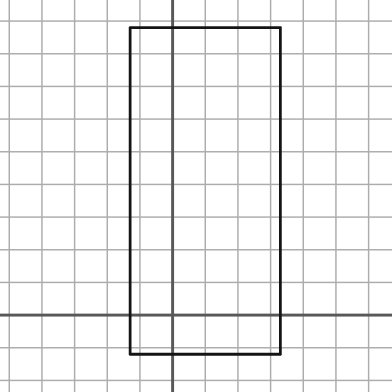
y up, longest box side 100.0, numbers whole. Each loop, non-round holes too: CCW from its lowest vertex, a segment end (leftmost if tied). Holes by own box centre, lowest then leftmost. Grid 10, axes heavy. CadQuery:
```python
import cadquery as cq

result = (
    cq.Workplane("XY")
    .moveTo(-13.0, -12.0)
    .lineTo(33.0, -12.0)
    .lineTo(33.0, 88.0)
    .lineTo(-13.0, 88.0)
    .close()
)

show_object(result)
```